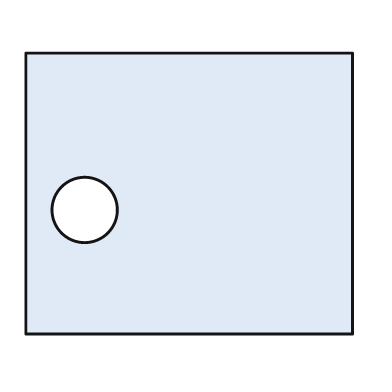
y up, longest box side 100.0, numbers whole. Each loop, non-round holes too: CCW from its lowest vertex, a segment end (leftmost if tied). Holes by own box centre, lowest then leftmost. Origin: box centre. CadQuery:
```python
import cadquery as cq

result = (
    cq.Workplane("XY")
    .moveTo(-50.0, -43.0)
    .lineTo(50.0, -43.0)
    .lineTo(50.0, 43.0)
    .lineTo(-50.0, 43.0)
    .close()
    .moveTo(-32.0, -5.0)
    .circle(10.0)
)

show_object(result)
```